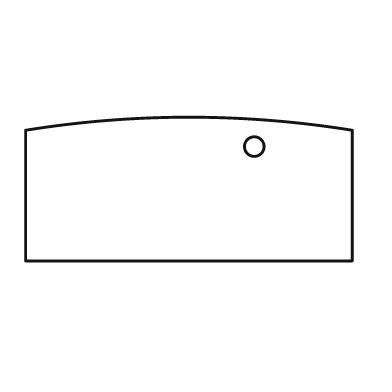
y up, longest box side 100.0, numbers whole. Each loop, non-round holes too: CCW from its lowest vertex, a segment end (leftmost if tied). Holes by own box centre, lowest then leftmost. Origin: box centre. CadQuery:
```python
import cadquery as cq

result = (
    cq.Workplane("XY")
    .moveTo(-50.0, -22.0)
    .lineTo(50.0, -22.0)
    .lineTo(50.0, 18.0)
    .threePointArc((0.0, 22.0), (-50.0, 18.0))
    .close()
    .moveTo(20.0, 13.0)
    .circle(3.0)
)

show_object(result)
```